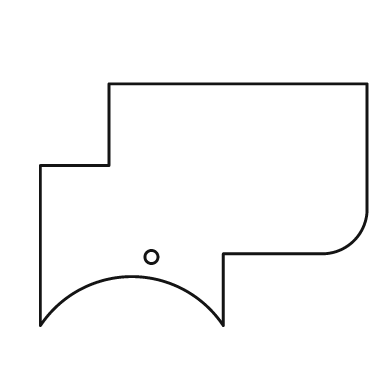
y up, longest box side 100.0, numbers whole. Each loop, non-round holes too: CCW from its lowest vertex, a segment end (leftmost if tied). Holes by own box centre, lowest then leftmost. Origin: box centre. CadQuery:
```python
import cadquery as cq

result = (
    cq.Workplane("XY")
    .moveTo(-50.0, -37.0)
    .threePointArc((-22.0, -22.0), (6.0, -37.0))
    .lineTo(6.0, -15.0)
    .lineTo(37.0, -15.0)
    .threePointArc((46.0, -11.0), (50.0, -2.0))
    .lineTo(50.0, 37.0)
    .lineTo(-29.0, 37.0)
    .lineTo(-29.0, 12.0)
    .lineTo(-50.0, 12.0)
    .close()
    .moveTo(-16.0, -16.0)
    .circle(2.0)
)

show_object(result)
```